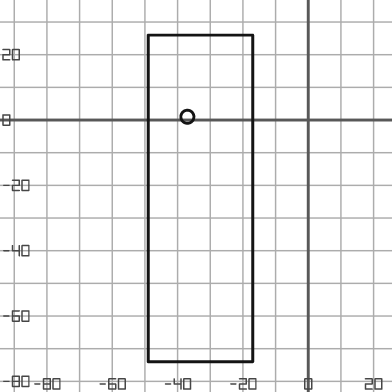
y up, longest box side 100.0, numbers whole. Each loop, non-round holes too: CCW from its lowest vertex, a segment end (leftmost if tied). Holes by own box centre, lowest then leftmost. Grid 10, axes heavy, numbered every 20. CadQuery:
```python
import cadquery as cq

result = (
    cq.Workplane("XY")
    .moveTo(-49.0, -74.0)
    .lineTo(-17.0, -74.0)
    .lineTo(-17.0, 26.0)
    .lineTo(-49.0, 26.0)
    .close()
    .moveTo(-37.0, 1.0)
    .circle(2.0)
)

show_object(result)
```